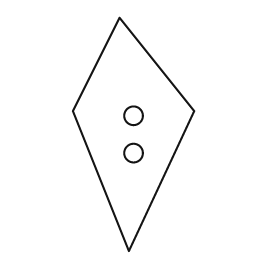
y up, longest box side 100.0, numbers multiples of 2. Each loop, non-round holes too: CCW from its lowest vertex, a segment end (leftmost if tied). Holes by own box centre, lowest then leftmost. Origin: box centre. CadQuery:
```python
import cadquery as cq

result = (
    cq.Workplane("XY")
    .moveTo(-2.0, -50.0)
    .lineTo(26.0, 10.0)
    .lineTo(-6.0, 50.0)
    .lineTo(-26.0, 10.0)
    .close()
    .moveTo(0.0, -8.0)
    .circle(4.0)
    .moveTo(0.0, 8.0)
    .circle(4.0)
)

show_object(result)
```